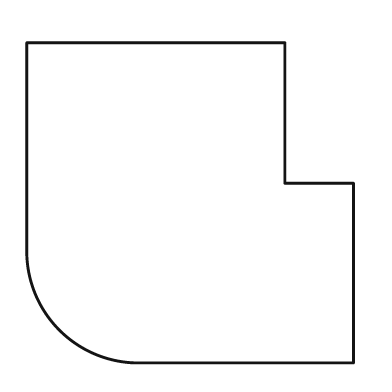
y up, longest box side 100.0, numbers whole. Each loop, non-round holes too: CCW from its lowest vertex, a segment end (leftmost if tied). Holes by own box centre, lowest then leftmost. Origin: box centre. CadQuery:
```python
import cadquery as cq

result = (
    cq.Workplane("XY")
    .moveTo(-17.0, -49.0)
    .lineTo(50.0, -49.0)
    .lineTo(50.0, 6.0)
    .lineTo(29.0, 6.0)
    .lineTo(29.0, 49.0)
    .lineTo(-50.0, 49.0)
    .lineTo(-50.0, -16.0)
    .threePointArc((-40.0, -39.0), (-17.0, -49.0))
    .close()
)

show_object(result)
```